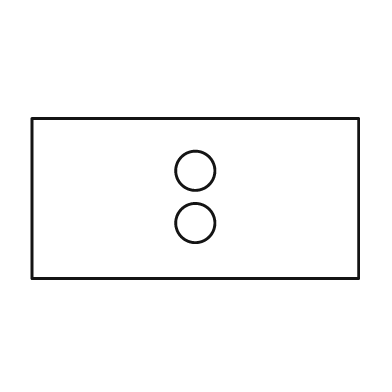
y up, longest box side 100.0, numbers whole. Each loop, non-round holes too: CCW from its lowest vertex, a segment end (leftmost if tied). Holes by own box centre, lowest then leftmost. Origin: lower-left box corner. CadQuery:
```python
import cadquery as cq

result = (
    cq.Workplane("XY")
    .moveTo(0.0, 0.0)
    .lineTo(100.0, 0.0)
    .lineTo(100.0, 49.0)
    .lineTo(0.0, 49.0)
    .close()
    .moveTo(50.0, 17.0)
    .circle(6.0)
    .moveTo(50.0, 33.0)
    .circle(6.0)
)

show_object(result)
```